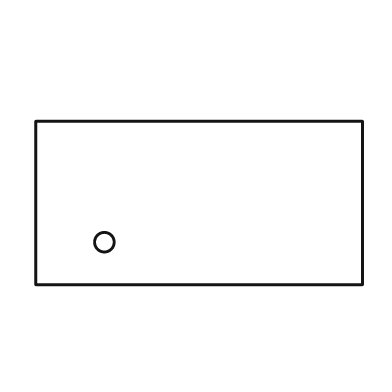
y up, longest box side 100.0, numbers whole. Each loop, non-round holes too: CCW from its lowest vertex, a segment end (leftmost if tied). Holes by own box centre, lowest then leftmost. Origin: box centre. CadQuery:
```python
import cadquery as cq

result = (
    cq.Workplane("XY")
    .moveTo(-50.0, -25.0)
    .lineTo(50.0, -25.0)
    .lineTo(50.0, 25.0)
    .lineTo(-50.0, 25.0)
    .close()
    .moveTo(-29.0, -12.0)
    .circle(3.0)
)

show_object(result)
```